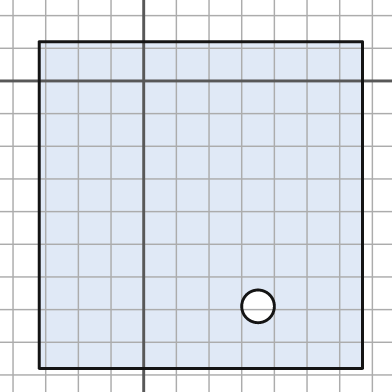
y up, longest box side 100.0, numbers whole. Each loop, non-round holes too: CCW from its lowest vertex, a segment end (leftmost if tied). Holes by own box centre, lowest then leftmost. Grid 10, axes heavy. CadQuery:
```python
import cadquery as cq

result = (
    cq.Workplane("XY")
    .moveTo(-32.0, -88.0)
    .lineTo(67.0, -88.0)
    .lineTo(67.0, 12.0)
    .lineTo(-32.0, 12.0)
    .close()
    .moveTo(35.0, -69.0)
    .circle(5.0)
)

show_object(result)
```